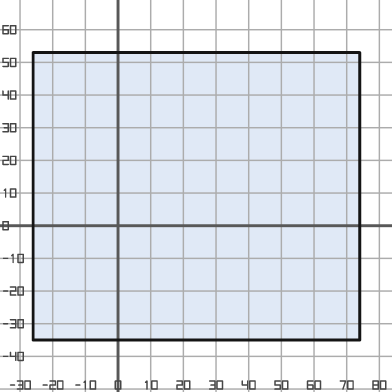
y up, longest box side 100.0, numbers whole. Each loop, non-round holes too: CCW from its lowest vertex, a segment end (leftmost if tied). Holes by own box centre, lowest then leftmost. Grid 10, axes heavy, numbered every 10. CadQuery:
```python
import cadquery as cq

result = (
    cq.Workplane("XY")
    .moveTo(-26.0, -35.0)
    .lineTo(74.0, -35.0)
    .lineTo(74.0, 53.0)
    .lineTo(-26.0, 53.0)
    .close()
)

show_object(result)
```